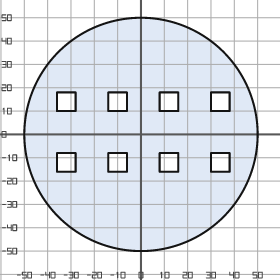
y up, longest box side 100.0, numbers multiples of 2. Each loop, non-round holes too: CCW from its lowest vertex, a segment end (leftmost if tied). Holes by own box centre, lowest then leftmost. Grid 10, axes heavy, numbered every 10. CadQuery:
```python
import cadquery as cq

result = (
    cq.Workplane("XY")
    .moveTo(0.0, 0.0)
    .circle(50.0)
    .moveTo(-36.0, -16.0)
    .lineTo(-28.0, -16.0)
    .lineTo(-28.0, -8.0)
    .lineTo(-36.0, -8.0)
    .close()
    .moveTo(-14.0, -16.0)
    .lineTo(-6.0, -16.0)
    .lineTo(-6.0, -8.0)
    .lineTo(-14.0, -8.0)
    .close()
    .moveTo(8.0, -16.0)
    .lineTo(16.0, -16.0)
    .lineTo(16.0, -8.0)
    .lineTo(8.0, -8.0)
    .close()
    .moveTo(30.0, -16.0)
    .lineTo(38.0, -16.0)
    .lineTo(38.0, -8.0)
    .lineTo(30.0, -8.0)
    .close()
    .moveTo(-36.0, 10.0)
    .lineTo(-28.0, 10.0)
    .lineTo(-28.0, 18.0)
    .lineTo(-36.0, 18.0)
    .close()
    .moveTo(-14.0, 10.0)
    .lineTo(-6.0, 10.0)
    .lineTo(-6.0, 18.0)
    .lineTo(-14.0, 18.0)
    .close()
    .moveTo(8.0, 10.0)
    .lineTo(16.0, 10.0)
    .lineTo(16.0, 18.0)
    .lineTo(8.0, 18.0)
    .close()
    .moveTo(30.0, 10.0)
    .lineTo(38.0, 10.0)
    .lineTo(38.0, 18.0)
    .lineTo(30.0, 18.0)
    .close()
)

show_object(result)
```